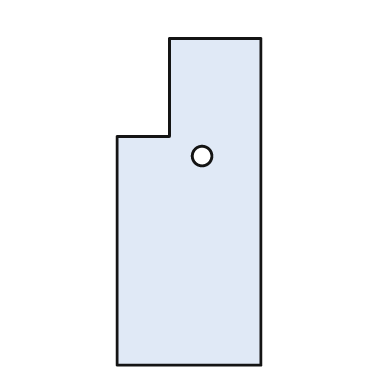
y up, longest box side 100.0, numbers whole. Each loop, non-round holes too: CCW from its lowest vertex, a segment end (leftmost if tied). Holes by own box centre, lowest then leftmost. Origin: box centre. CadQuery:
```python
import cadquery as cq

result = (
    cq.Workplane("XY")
    .moveTo(-22.0, -50.0)
    .lineTo(22.0, -50.0)
    .lineTo(22.0, 50.0)
    .lineTo(-6.0, 50.0)
    .lineTo(-6.0, 20.0)
    .lineTo(-22.0, 20.0)
    .close()
    .moveTo(4.0, 14.0)
    .circle(3.0)
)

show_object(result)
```